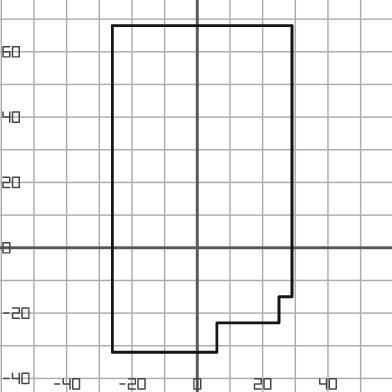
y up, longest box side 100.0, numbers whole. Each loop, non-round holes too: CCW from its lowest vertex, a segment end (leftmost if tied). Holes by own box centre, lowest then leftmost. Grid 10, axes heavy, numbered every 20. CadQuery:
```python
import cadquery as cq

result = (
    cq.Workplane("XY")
    .moveTo(-26.0, -32.0)
    .lineTo(6.0, -32.0)
    .lineTo(6.0, -23.0)
    .lineTo(25.0, -23.0)
    .lineTo(25.0, -15.0)
    .lineTo(29.0, -15.0)
    .lineTo(29.0, 68.0)
    .lineTo(-26.0, 68.0)
    .close()
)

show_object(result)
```